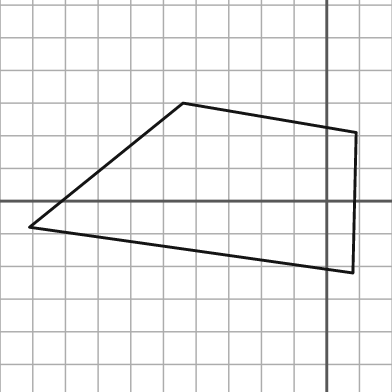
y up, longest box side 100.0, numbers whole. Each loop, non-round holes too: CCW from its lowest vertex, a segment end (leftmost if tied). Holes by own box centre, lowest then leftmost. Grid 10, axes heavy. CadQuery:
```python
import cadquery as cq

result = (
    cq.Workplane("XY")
    .moveTo(8.0, -22.0)
    .lineTo(9.0, 21.0)
    .lineTo(-44.0, 30.0)
    .lineTo(-91.0, -8.0)
    .close()
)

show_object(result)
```